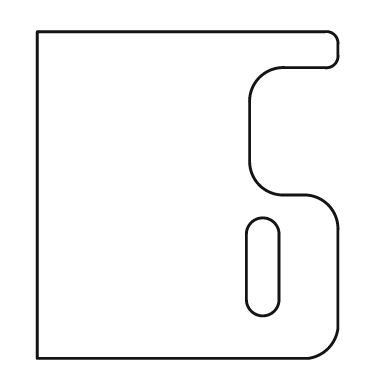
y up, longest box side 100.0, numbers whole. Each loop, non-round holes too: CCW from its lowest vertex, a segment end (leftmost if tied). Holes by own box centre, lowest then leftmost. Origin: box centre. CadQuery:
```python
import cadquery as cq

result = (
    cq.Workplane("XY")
    .moveTo(-46.0, -50.0)
    .lineTo(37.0, -50.0)
    .threePointArc((43.0, -47.0), (46.0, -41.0))
    .lineTo(46.0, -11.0)
    .threePointArc((43.0, -3.0), (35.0, 0.0))
    .lineTo(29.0, 0.0)
    .threePointArc((22.0, 3.0), (19.0, 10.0))
    .lineTo(19.0, 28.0)
    .threePointArc((22.0, 36.0), (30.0, 39.0))
    .lineTo(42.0, 39.0)
    .threePointArc((45.0, 40.0), (46.0, 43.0))
    .lineTo(46.0, 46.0)
    .threePointArc((45.0, 49.0), (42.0, 50.0))
    .lineTo(-46.0, 50.0)
    .close()
    .moveTo(18.0, -32.0)
    .threePointArc((23.0, -37.0), (28.0, -32.0))
    .lineTo(28.0, -12.0)
    .threePointArc((23.0, -7.0), (18.0, -12.0))
    .close()
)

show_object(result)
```